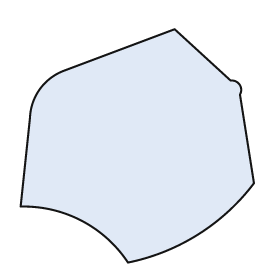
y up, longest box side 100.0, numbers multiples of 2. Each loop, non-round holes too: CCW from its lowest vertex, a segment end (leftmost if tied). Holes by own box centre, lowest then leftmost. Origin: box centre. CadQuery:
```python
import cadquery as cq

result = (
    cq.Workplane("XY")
    .moveTo(-4.0, -50.0)
    .threePointArc((26.0, -38.0), (50.0, -16.0))
    .lineTo(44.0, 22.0)
    .threePointArc((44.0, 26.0), (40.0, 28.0))
    .lineTo(16.0, 50.0)
    .lineTo(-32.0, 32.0)
    .threePointArc((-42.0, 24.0), (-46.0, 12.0))
    .lineTo(-50.0, -26.0)
    .threePointArc((-24.0, -32.0), (-4.0, -50.0))
    .close()
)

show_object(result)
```